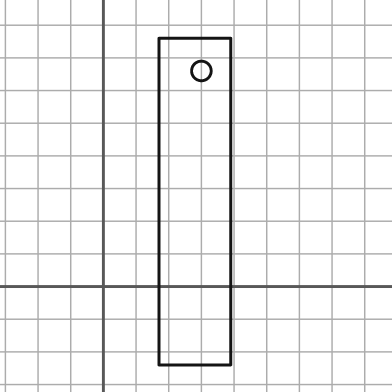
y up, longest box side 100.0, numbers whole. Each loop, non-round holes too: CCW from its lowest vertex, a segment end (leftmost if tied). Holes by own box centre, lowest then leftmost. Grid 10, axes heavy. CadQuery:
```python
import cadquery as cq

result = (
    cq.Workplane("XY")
    .moveTo(17.0, -24.0)
    .lineTo(39.0, -24.0)
    .lineTo(39.0, 76.0)
    .lineTo(17.0, 76.0)
    .close()
    .moveTo(30.0, 66.0)
    .circle(3.0)
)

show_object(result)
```